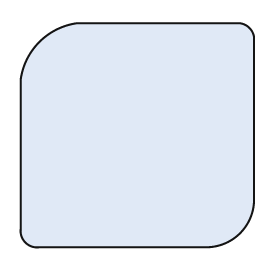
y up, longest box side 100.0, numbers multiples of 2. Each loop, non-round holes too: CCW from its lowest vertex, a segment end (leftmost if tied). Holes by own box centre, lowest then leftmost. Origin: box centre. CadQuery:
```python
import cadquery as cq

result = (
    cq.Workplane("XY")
    .moveTo(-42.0, -48.0)
    .lineTo(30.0, -48.0)
    .threePointArc((44.0, -42.0), (50.0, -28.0))
    .lineTo(50.0, 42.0)
    .threePointArc((48.0, 46.0), (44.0, 48.0))
    .lineTo(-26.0, 48.0)
    .threePointArc((-42.0, 40.0), (-50.0, 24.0))
    .lineTo(-50.0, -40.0)
    .threePointArc((-48.0, -46.0), (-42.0, -48.0))
    .close()
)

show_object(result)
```